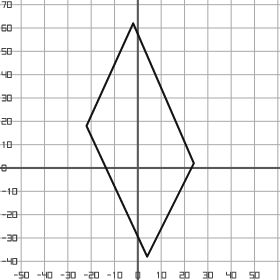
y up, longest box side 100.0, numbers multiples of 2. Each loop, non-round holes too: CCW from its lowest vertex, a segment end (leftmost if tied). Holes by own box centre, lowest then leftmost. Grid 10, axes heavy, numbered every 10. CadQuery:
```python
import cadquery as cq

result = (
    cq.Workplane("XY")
    .moveTo(4.0, -38.0)
    .lineTo(24.0, 2.0)
    .lineTo(-2.0, 62.0)
    .lineTo(-22.0, 18.0)
    .close()
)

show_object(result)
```